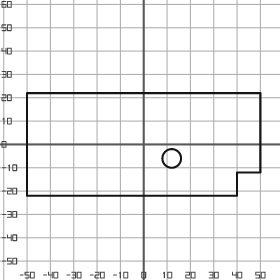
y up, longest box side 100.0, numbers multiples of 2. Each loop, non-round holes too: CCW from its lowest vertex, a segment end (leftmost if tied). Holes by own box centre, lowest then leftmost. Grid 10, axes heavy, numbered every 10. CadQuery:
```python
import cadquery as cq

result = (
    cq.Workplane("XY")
    .moveTo(-50.0, -22.0)
    .lineTo(40.0, -22.0)
    .lineTo(40.0, -12.0)
    .lineTo(50.0, -12.0)
    .lineTo(50.0, 22.0)
    .lineTo(-50.0, 22.0)
    .close()
    .moveTo(12.0, -6.0)
    .circle(4.0)
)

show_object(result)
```